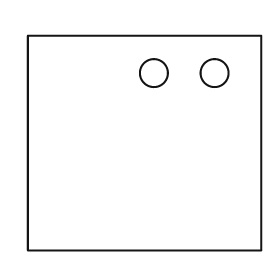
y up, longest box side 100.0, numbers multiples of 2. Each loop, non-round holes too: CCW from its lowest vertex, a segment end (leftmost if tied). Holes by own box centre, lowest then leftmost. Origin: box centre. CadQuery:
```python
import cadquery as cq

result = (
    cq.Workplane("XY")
    .moveTo(-50.0, -46.0)
    .lineTo(50.0, -46.0)
    .lineTo(50.0, 46.0)
    .lineTo(-50.0, 46.0)
    .close()
    .moveTo(4.0, 30.0)
    .circle(6.0)
    .moveTo(30.0, 30.0)
    .circle(6.0)
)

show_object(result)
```